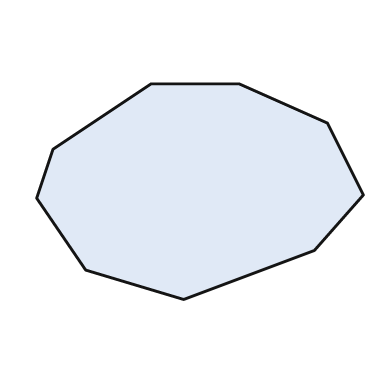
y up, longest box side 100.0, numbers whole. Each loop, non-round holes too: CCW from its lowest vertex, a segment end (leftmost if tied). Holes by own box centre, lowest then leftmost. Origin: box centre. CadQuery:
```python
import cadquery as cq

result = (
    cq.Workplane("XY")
    .moveTo(-5.0, -33.0)
    .lineTo(35.0, -18.0)
    .lineTo(50.0, -1.0)
    .lineTo(39.0, 21.0)
    .lineTo(12.0, 33.0)
    .lineTo(-15.0, 33.0)
    .lineTo(-45.0, 13.0)
    .lineTo(-50.0, -2.0)
    .lineTo(-35.0, -24.0)
    .close()
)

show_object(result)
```